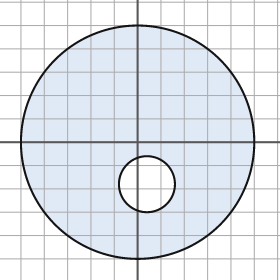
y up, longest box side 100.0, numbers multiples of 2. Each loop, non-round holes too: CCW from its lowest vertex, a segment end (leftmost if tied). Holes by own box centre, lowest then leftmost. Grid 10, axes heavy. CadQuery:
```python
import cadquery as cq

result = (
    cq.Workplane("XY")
    .moveTo(0.0, 0.0)
    .circle(50.0)
    .moveTo(4.0, -18.0)
    .circle(12.0)
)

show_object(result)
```